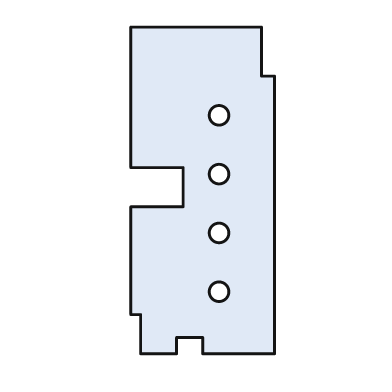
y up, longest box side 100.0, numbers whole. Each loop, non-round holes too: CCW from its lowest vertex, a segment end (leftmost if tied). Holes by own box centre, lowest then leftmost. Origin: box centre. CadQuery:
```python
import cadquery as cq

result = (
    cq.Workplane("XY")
    .moveTo(-19.0, -50.0)
    .lineTo(-8.0, -50.0)
    .lineTo(-8.0, -45.0)
    .lineTo(0.0, -45.0)
    .lineTo(0.0, -50.0)
    .lineTo(22.0, -50.0)
    .lineTo(22.0, 35.0)
    .lineTo(18.0, 35.0)
    .lineTo(18.0, 50.0)
    .lineTo(-22.0, 50.0)
    .lineTo(-22.0, 7.0)
    .lineTo(-6.0, 7.0)
    .lineTo(-6.0, -5.0)
    .lineTo(-22.0, -5.0)
    .lineTo(-22.0, -38.0)
    .lineTo(-19.0, -38.0)
    .close()
    .moveTo(5.0, -31.0)
    .circle(3.0)
    .moveTo(5.0, -13.0)
    .circle(3.0)
    .moveTo(5.0, 5.0)
    .circle(3.0)
    .moveTo(5.0, 23.0)
    .circle(3.0)
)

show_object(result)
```